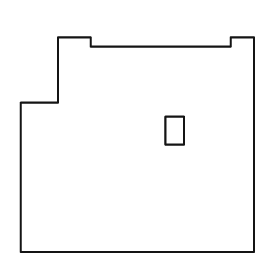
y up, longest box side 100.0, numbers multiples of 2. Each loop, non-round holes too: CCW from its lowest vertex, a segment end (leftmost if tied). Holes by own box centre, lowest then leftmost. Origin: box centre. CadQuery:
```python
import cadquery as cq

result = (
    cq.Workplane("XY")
    .moveTo(-50.0, -46.0)
    .lineTo(50.0, -46.0)
    .lineTo(50.0, 46.0)
    .lineTo(40.0, 46.0)
    .lineTo(40.0, 42.0)
    .lineTo(-20.0, 42.0)
    .lineTo(-20.0, 46.0)
    .lineTo(-34.0, 46.0)
    .lineTo(-34.0, 18.0)
    .lineTo(-50.0, 18.0)
    .close()
    .moveTo(12.0, 0.0)
    .lineTo(20.0, 0.0)
    .lineTo(20.0, 12.0)
    .lineTo(12.0, 12.0)
    .close()
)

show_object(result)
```